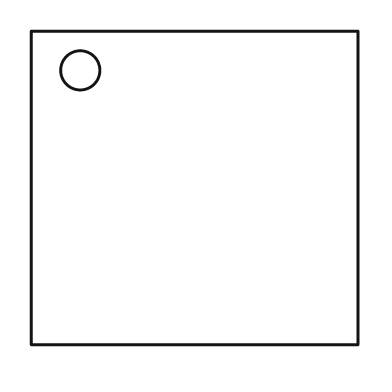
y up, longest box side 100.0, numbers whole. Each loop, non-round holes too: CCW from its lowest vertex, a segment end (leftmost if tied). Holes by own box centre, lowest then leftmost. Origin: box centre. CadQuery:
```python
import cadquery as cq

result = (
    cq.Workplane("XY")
    .moveTo(-50.0, -48.0)
    .lineTo(50.0, -48.0)
    .lineTo(50.0, 48.0)
    .lineTo(-50.0, 48.0)
    .close()
    .moveTo(-35.0, 36.0)
    .circle(6.0)
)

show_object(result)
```